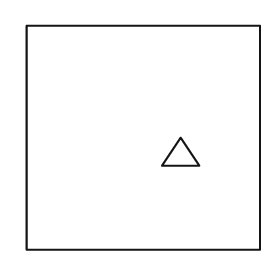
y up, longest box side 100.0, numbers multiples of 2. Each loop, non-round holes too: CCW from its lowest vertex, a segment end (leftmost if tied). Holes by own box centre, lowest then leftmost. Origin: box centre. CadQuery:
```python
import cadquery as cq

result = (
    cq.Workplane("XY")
    .moveTo(-50.0, -48.0)
    .lineTo(50.0, -48.0)
    .lineTo(50.0, 48.0)
    .lineTo(-50.0, 48.0)
    .close()
    .moveTo(8.0, -12.0)
    .lineTo(24.0, -12.0)
    .lineTo(16.0, 0.0)
    .close()
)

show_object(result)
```